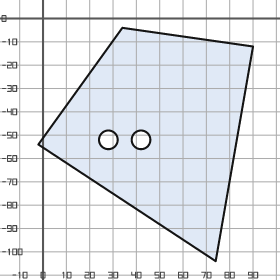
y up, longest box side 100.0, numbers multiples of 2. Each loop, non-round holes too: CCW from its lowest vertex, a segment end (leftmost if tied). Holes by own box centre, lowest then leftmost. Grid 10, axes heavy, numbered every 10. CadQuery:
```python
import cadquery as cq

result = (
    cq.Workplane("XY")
    .moveTo(74.0, -104.0)
    .lineTo(90.0, -12.0)
    .lineTo(34.0, -4.0)
    .lineTo(-2.0, -54.0)
    .close()
    .moveTo(28.0, -52.0)
    .circle(4.0)
    .moveTo(42.0, -52.0)
    .circle(4.0)
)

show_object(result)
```